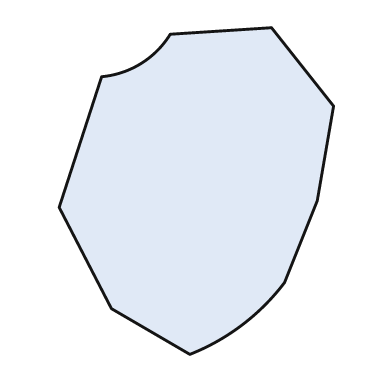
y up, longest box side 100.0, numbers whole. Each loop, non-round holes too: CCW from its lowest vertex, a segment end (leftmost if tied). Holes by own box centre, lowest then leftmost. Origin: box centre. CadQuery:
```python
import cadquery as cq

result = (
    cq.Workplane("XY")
    .moveTo(-2.0, -50.0)
    .threePointArc((14.0, -41.0), (27.0, -28.0))
    .lineTo(37.0, -3.0)
    .lineTo(42.0, 26.0)
    .lineTo(23.0, 50.0)
    .lineTo(-8.0, 48.0)
    .threePointArc((-17.0, 39.0), (-29.0, 35.0))
    .lineTo(-42.0, -5.0)
    .lineTo(-26.0, -36.0)
    .close()
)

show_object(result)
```